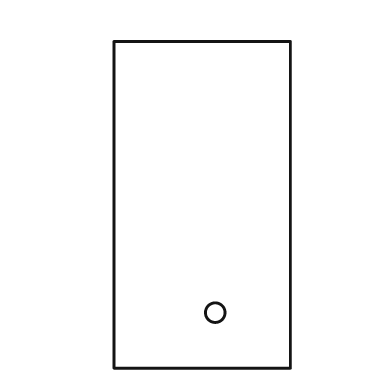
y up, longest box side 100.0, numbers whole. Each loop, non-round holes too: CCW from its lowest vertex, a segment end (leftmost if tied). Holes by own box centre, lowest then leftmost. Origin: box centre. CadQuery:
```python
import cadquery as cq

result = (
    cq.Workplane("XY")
    .moveTo(-27.0, -50.0)
    .lineTo(27.0, -50.0)
    .lineTo(27.0, 50.0)
    .lineTo(-27.0, 50.0)
    .close()
    .moveTo(4.0, -33.0)
    .circle(3.0)
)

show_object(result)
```